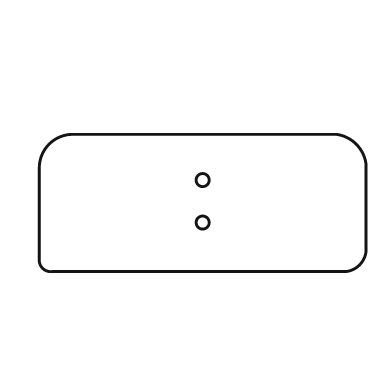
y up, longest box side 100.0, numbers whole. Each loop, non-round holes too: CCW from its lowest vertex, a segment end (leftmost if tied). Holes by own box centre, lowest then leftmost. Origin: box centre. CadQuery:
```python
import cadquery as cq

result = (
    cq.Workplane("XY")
    .moveTo(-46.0, -21.0)
    .lineTo(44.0, -21.0)
    .threePointArc((48.0, -19.0), (50.0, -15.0))
    .lineTo(50.0, 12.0)
    .threePointArc((47.0, 18.0), (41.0, 21.0))
    .lineTo(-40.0, 21.0)
    .threePointArc((-47.0, 18.0), (-50.0, 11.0))
    .lineTo(-50.0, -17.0)
    .threePointArc((-49.0, -20.0), (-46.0, -21.0))
    .close()
    .moveTo(0.0, -6.0)
    .circle(2.0)
    .moveTo(0.0, 7.0)
    .circle(2.0)
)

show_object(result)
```